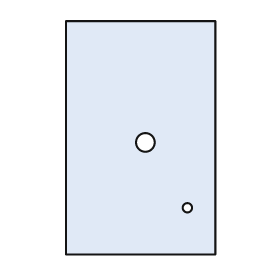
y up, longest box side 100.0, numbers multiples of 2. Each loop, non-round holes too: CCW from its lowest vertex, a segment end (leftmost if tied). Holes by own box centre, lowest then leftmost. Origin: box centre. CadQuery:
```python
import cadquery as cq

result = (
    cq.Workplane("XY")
    .moveTo(-32.0, -50.0)
    .lineTo(32.0, -50.0)
    .lineTo(32.0, 50.0)
    .lineTo(-32.0, 50.0)
    .close()
    .moveTo(20.0, -30.0)
    .circle(2.0)
    .moveTo(2.0, -2.0)
    .circle(4.0)
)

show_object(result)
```